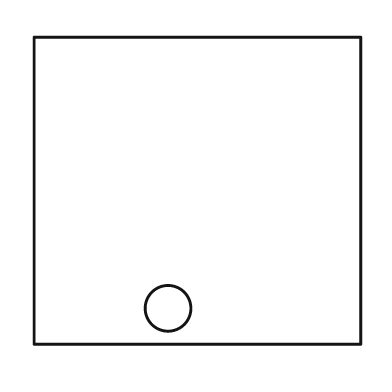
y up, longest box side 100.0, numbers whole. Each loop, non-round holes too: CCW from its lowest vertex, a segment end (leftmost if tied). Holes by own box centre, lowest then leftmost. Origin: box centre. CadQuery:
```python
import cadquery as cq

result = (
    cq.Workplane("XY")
    .moveTo(-50.0, -47.0)
    .lineTo(50.0, -47.0)
    .lineTo(50.0, 47.0)
    .lineTo(-50.0, 47.0)
    .close()
    .moveTo(-9.0, -36.0)
    .circle(7.0)
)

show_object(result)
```